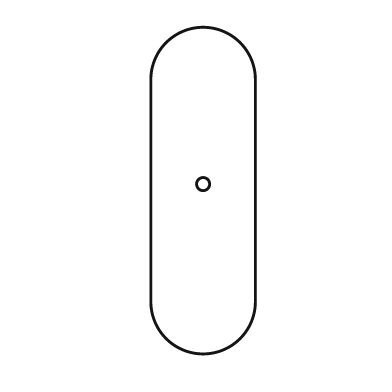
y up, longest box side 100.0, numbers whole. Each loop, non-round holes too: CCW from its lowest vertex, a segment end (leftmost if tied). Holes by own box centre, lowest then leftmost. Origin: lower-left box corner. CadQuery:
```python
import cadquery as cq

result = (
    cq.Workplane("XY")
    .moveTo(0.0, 16.0)
    .threePointArc((16.0, 0.0), (32.0, 16.0))
    .lineTo(32.0, 84.0)
    .threePointArc((16.0, 100.0), (0.0, 84.0))
    .close()
    .moveTo(16.0, 52.0)
    .circle(2.0)
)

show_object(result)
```